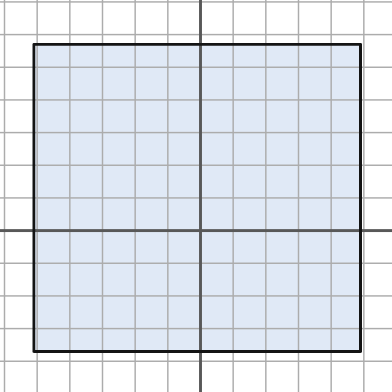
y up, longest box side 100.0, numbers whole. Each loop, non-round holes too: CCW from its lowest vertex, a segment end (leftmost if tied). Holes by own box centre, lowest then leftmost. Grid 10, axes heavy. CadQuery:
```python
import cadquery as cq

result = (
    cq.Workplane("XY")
    .moveTo(-51.0, -37.0)
    .lineTo(49.0, -37.0)
    .lineTo(49.0, 57.0)
    .lineTo(-51.0, 57.0)
    .close()
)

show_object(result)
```